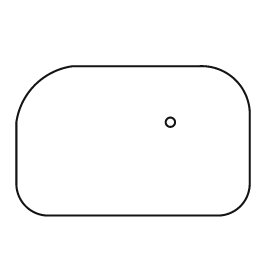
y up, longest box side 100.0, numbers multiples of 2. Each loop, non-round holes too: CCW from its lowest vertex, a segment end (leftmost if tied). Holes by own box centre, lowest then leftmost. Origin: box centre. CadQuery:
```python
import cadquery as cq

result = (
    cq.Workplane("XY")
    .moveTo(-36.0, -32.0)
    .lineTo(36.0, -32.0)
    .threePointArc((46.0, -28.0), (50.0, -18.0))
    .lineTo(50.0, 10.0)
    .threePointArc((44.0, 26.0), (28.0, 32.0))
    .lineTo(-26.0, 32.0)
    .threePointArc((-42.0, 24.0), (-50.0, 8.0))
    .lineTo(-50.0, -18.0)
    .threePointArc((-46.0, -28.0), (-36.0, -32.0))
    .close()
    .moveTo(16.0, 8.0)
    .circle(2.0)
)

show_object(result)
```